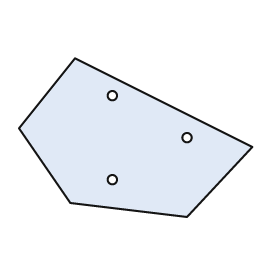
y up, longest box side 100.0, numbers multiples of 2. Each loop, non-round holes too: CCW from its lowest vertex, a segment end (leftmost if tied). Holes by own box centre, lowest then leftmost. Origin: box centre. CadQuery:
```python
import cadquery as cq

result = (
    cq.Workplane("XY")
    .moveTo(22.0, -34.0)
    .lineTo(50.0, -4.0)
    .lineTo(-26.0, 34.0)
    .lineTo(-50.0, 4.0)
    .lineTo(-28.0, -28.0)
    .close()
    .moveTo(-10.0, -18.0)
    .circle(2.0)
    .moveTo(22.0, 0.0)
    .circle(2.0)
    .moveTo(-10.0, 18.0)
    .circle(2.0)
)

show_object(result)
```